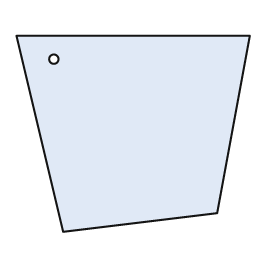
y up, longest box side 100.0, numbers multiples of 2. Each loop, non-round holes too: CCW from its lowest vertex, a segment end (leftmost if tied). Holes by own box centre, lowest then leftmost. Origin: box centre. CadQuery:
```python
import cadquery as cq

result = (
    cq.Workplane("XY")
    .moveTo(-30.0, -42.0)
    .lineTo(36.0, -34.0)
    .lineTo(50.0, 42.0)
    .lineTo(-50.0, 42.0)
    .close()
    .moveTo(-34.0, 32.0)
    .circle(2.0)
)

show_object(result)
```